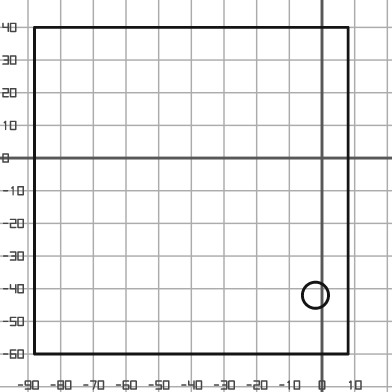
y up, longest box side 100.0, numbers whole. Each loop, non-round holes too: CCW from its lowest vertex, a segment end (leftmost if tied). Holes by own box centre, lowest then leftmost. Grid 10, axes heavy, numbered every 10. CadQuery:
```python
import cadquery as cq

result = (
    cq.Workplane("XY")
    .moveTo(-88.0, -60.0)
    .lineTo(8.0, -60.0)
    .lineTo(8.0, 40.0)
    .lineTo(-88.0, 40.0)
    .close()
    .moveTo(-2.0, -42.0)
    .circle(4.0)
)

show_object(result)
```